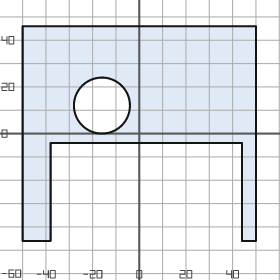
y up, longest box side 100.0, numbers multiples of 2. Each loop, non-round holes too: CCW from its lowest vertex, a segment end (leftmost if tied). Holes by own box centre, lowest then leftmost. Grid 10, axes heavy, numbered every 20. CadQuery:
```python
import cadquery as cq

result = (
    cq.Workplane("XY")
    .moveTo(-50.0, -46.0)
    .lineTo(-38.0, -46.0)
    .lineTo(-38.0, -4.0)
    .lineTo(44.0, -4.0)
    .lineTo(44.0, -46.0)
    .lineTo(50.0, -46.0)
    .lineTo(50.0, 46.0)
    .lineTo(-50.0, 46.0)
    .close()
    .moveTo(-16.0, 12.0)
    .circle(12.0)
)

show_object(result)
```